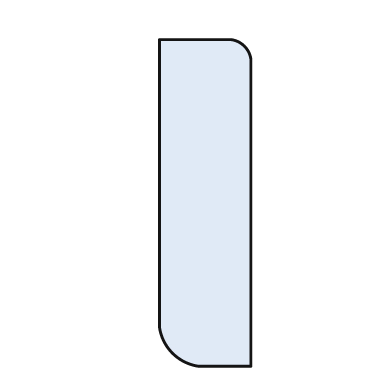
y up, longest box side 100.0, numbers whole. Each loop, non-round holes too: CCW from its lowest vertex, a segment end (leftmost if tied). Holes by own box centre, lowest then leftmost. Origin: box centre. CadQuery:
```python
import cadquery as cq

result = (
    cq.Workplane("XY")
    .moveTo(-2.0, -50.0)
    .lineTo(14.0, -50.0)
    .lineTo(14.0, 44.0)
    .threePointArc((12.0, 48.0), (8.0, 50.0))
    .lineTo(-14.0, 50.0)
    .lineTo(-14.0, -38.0)
    .threePointArc((-10.0, -46.0), (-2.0, -50.0))
    .close()
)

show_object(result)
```